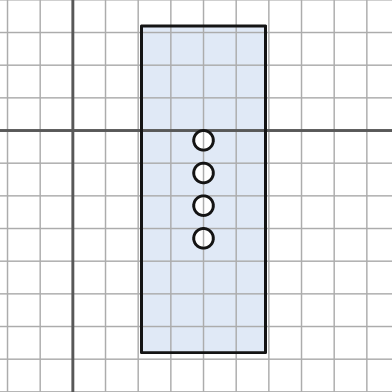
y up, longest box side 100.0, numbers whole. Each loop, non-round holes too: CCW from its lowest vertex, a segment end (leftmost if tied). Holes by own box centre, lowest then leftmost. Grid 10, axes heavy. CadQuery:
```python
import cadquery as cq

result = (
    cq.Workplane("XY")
    .moveTo(21.0, -68.0)
    .lineTo(59.0, -68.0)
    .lineTo(59.0, 32.0)
    .lineTo(21.0, 32.0)
    .close()
    .moveTo(40.0, -33.0)
    .circle(3.0)
    .moveTo(40.0, -23.0)
    .circle(3.0)
    .moveTo(40.0, -13.0)
    .circle(3.0)
    .moveTo(40.0, -3.0)
    .circle(3.0)
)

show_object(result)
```